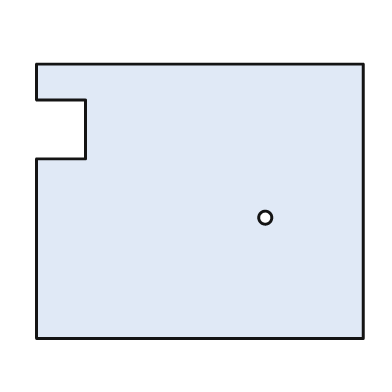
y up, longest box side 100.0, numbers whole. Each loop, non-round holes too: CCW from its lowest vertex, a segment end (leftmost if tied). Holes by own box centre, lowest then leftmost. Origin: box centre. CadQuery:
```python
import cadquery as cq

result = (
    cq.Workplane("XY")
    .moveTo(-50.0, -42.0)
    .lineTo(50.0, -42.0)
    .lineTo(50.0, 42.0)
    .lineTo(-50.0, 42.0)
    .lineTo(-50.0, 31.0)
    .lineTo(-35.0, 31.0)
    .lineTo(-35.0, 13.0)
    .lineTo(-50.0, 13.0)
    .close()
    .moveTo(20.0, -5.0)
    .circle(2.0)
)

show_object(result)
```